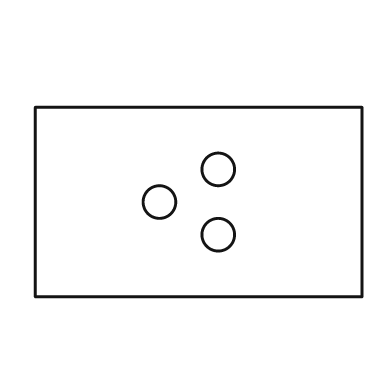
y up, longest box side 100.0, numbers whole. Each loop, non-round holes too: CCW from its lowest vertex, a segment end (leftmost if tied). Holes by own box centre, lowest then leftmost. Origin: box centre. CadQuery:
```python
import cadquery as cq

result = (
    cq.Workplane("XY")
    .moveTo(-50.0, -29.0)
    .lineTo(50.0, -29.0)
    .lineTo(50.0, 29.0)
    .lineTo(-50.0, 29.0)
    .close()
    .moveTo(6.0, -10.0)
    .circle(5.0)
    .moveTo(-12.0, 0.0)
    .circle(5.0)
    .moveTo(6.0, 10.0)
    .circle(5.0)
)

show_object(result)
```